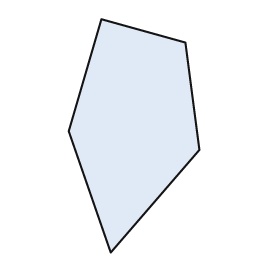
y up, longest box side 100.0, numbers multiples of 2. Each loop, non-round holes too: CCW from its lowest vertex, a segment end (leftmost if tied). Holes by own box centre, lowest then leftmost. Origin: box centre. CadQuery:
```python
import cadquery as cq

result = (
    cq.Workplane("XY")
    .moveTo(-10.0, -50.0)
    .lineTo(28.0, -6.0)
    .lineTo(22.0, 40.0)
    .lineTo(-14.0, 50.0)
    .lineTo(-28.0, 2.0)
    .close()
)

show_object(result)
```